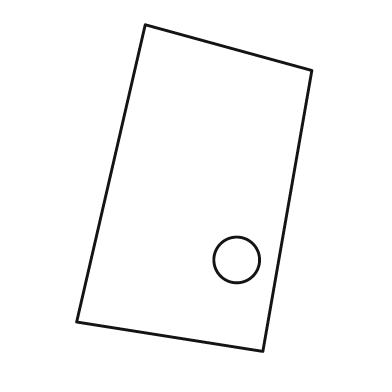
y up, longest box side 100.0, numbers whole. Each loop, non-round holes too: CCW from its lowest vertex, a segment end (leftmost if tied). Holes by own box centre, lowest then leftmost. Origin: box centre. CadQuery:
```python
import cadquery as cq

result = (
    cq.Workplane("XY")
    .moveTo(21.0, -50.0)
    .lineTo(36.0, 36.0)
    .lineTo(-15.0, 50.0)
    .lineTo(-36.0, -41.0)
    .close()
    .moveTo(13.0, -22.0)
    .circle(7.0)
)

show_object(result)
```